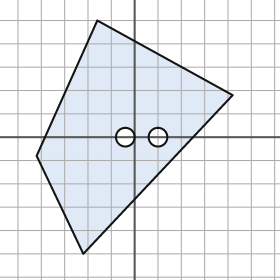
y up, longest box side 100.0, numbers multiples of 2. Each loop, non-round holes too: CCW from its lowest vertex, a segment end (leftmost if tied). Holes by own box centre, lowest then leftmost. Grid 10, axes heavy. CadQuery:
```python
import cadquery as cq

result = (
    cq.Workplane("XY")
    .moveTo(-22.0, -50.0)
    .lineTo(42.0, 18.0)
    .lineTo(-16.0, 50.0)
    .lineTo(-42.0, -8.0)
    .close()
    .moveTo(-4.0, 0.0)
    .circle(4.0)
    .moveTo(10.0, 0.0)
    .circle(4.0)
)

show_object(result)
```